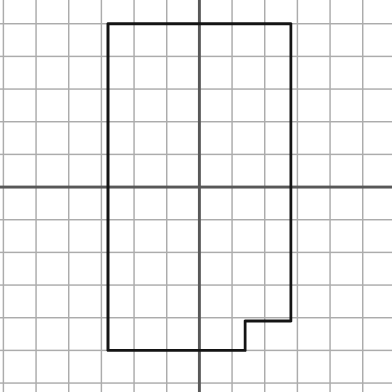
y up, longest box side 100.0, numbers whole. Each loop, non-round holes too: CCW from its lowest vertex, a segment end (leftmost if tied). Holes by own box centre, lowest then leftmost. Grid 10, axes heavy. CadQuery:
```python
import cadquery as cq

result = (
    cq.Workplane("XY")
    .moveTo(-28.0, -50.0)
    .lineTo(14.0, -50.0)
    .lineTo(14.0, -41.0)
    .lineTo(28.0, -41.0)
    .lineTo(28.0, 50.0)
    .lineTo(-28.0, 50.0)
    .close()
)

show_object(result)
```